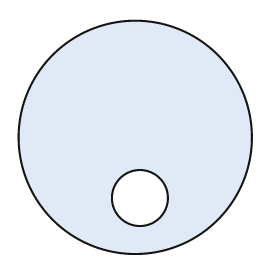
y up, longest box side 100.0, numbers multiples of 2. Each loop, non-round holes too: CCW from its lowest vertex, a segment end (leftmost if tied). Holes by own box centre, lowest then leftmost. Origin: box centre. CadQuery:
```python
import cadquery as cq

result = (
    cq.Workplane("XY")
    .moveTo(0.0, 0.0)
    .circle(50.0)
    .moveTo(2.0, -26.0)
    .circle(12.0)
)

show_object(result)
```